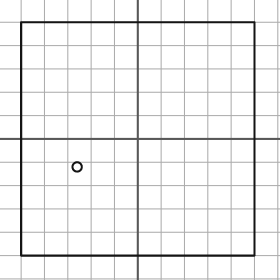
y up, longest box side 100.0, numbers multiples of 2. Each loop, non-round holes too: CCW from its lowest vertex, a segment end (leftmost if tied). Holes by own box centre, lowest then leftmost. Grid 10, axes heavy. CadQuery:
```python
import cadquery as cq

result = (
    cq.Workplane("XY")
    .moveTo(-50.0, -50.0)
    .lineTo(50.0, -50.0)
    .lineTo(50.0, 50.0)
    .lineTo(-50.0, 50.0)
    .close()
    .moveTo(-26.0, -12.0)
    .circle(2.0)
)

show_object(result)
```